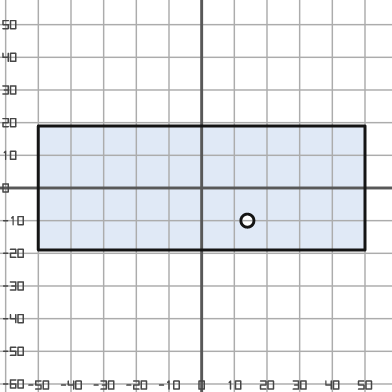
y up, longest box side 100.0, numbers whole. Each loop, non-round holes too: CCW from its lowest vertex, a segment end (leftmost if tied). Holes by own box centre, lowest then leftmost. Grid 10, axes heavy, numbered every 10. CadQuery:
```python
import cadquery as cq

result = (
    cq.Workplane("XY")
    .moveTo(-50.0, -19.0)
    .lineTo(50.0, -19.0)
    .lineTo(50.0, 19.0)
    .lineTo(-50.0, 19.0)
    .close()
    .moveTo(14.0, -10.0)
    .circle(2.0)
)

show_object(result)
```